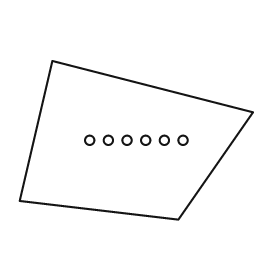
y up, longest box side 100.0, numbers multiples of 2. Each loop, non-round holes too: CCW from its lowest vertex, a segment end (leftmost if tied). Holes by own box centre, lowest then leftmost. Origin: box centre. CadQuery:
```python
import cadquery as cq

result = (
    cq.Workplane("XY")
    .moveTo(18.0, -34.0)
    .lineTo(50.0, 12.0)
    .lineTo(-36.0, 34.0)
    .lineTo(-50.0, -26.0)
    .close()
    .moveTo(-20.0, 0.0)
    .circle(2.0)
    .moveTo(-12.0, 0.0)
    .circle(2.0)
    .moveTo(-4.0, 0.0)
    .circle(2.0)
    .moveTo(4.0, 0.0)
    .circle(2.0)
    .moveTo(12.0, 0.0)
    .circle(2.0)
    .moveTo(20.0, 0.0)
    .circle(2.0)
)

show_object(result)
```